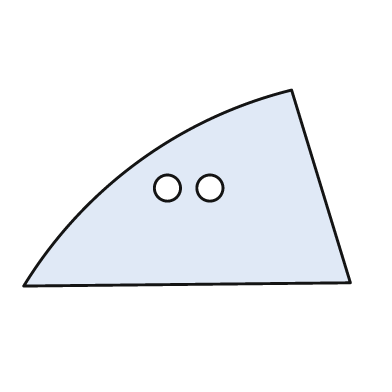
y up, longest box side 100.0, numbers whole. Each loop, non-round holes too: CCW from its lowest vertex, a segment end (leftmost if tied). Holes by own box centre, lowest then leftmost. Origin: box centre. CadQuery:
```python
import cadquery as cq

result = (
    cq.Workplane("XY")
    .moveTo(-50.0, -30.0)
    .lineTo(50.0, -29.0)
    .lineTo(32.0, 30.0)
    .threePointArc((-15.0, 8.0), (-50.0, -30.0))
    .close()
    .moveTo(-6.0, 0.0)
    .circle(4.0)
    .moveTo(7.0, 0.0)
    .circle(4.0)
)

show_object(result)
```